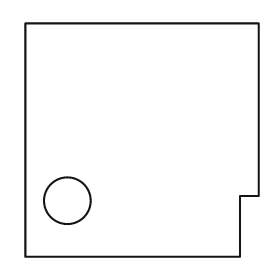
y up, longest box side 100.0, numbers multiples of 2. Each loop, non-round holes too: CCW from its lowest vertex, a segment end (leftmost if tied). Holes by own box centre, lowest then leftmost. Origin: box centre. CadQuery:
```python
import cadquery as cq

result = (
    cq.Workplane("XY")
    .moveTo(-50.0, -50.0)
    .lineTo(42.0, -50.0)
    .lineTo(42.0, -24.0)
    .lineTo(50.0, -24.0)
    .lineTo(50.0, 50.0)
    .lineTo(-50.0, 50.0)
    .close()
    .moveTo(-32.0, -26.0)
    .circle(10.0)
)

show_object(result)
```